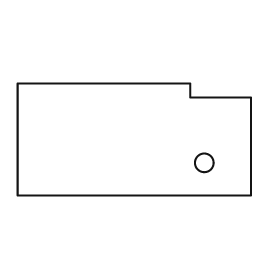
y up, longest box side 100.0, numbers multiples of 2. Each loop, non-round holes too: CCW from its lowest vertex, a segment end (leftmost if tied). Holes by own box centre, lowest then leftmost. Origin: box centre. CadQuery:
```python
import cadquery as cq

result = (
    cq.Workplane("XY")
    .moveTo(-50.0, -24.0)
    .lineTo(50.0, -24.0)
    .lineTo(50.0, 18.0)
    .lineTo(24.0, 18.0)
    .lineTo(24.0, 24.0)
    .lineTo(-50.0, 24.0)
    .close()
    .moveTo(30.0, -10.0)
    .circle(4.0)
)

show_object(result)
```